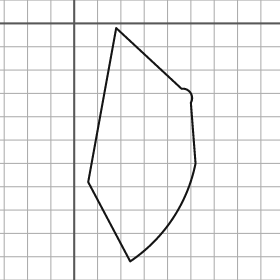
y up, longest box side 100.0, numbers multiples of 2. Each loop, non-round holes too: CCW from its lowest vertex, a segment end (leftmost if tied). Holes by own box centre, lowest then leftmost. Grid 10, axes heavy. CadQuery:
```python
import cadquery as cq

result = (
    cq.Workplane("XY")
    .moveTo(24.0, -102.0)
    .threePointArc((42.0, -84.0), (52.0, -60.0))
    .lineTo(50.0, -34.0)
    .threePointArc((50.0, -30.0), (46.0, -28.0))
    .lineTo(18.0, -2.0)
    .lineTo(6.0, -68.0)
    .close()
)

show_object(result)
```